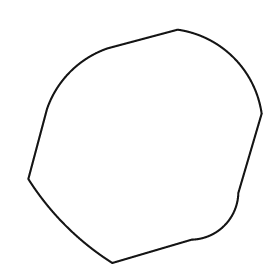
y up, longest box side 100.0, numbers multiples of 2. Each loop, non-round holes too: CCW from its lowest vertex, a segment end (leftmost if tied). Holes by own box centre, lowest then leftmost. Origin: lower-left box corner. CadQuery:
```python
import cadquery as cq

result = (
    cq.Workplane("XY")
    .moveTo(36.0, 0.0)
    .lineTo(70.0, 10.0)
    .threePointArc((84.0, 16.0), (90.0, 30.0))
    .lineTo(100.0, 64.0)
    .threePointArc((88.0, 88.0), (64.0, 100.0))
    .lineTo(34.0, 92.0)
    .threePointArc((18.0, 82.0), (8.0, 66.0))
    .lineTo(0.0, 36.0)
    .threePointArc((16.0, 16.0), (36.0, 0.0))
    .close()
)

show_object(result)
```